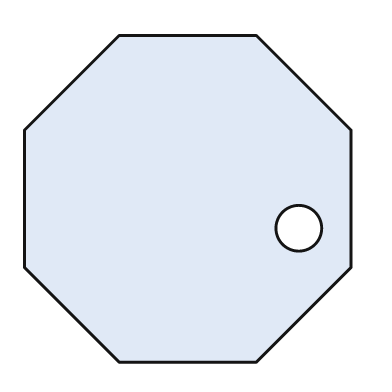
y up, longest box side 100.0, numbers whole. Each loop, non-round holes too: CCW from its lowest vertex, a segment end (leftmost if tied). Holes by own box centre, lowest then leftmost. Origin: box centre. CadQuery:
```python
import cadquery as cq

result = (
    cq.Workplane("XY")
    .moveTo(-21.0, -50.0)
    .lineTo(21.0, -50.0)
    .lineTo(50.0, -21.0)
    .lineTo(50.0, 21.0)
    .lineTo(21.0, 50.0)
    .lineTo(-21.0, 50.0)
    .lineTo(-50.0, 21.0)
    .lineTo(-50.0, -21.0)
    .close()
    .moveTo(34.0, -9.0)
    .circle(7.0)
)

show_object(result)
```